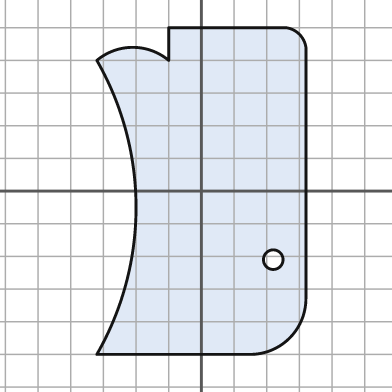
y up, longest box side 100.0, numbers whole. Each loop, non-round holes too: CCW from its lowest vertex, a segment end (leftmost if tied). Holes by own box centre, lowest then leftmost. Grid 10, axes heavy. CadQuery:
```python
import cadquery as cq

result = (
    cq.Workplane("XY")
    .moveTo(-32.0, -50.0)
    .lineTo(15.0, -50.0)
    .threePointArc((27.0, -45.0), (32.0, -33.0))
    .lineTo(32.0, 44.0)
    .threePointArc((30.0, 48.0), (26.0, 50.0))
    .lineTo(-10.0, 50.0)
    .lineTo(-10.0, 40.0)
    .threePointArc((-21.0, 44.0), (-32.0, 40.0))
    .threePointArc((-20.0, -5.0), (-32.0, -50.0))
    .close()
    .moveTo(22.0, -21.0)
    .circle(3.0)
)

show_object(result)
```